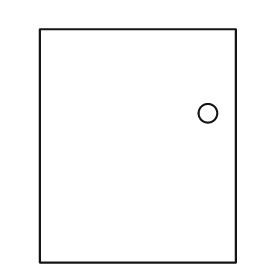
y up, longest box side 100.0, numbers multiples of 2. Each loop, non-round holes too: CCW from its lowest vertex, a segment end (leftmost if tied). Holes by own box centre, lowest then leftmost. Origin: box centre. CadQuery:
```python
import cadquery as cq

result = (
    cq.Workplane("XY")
    .moveTo(-42.0, -50.0)
    .lineTo(42.0, -50.0)
    .lineTo(42.0, 50.0)
    .lineTo(-42.0, 50.0)
    .close()
    .moveTo(30.0, 14.0)
    .circle(4.0)
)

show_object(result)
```